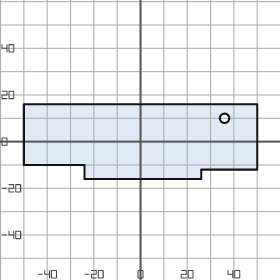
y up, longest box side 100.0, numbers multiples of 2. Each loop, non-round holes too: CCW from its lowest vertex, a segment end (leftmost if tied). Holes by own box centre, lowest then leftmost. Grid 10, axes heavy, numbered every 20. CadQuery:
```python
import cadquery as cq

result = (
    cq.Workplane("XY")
    .moveTo(-24.0, -16.0)
    .lineTo(26.0, -16.0)
    .lineTo(26.0, -12.0)
    .lineTo(50.0, -12.0)
    .lineTo(50.0, 16.0)
    .lineTo(-50.0, 16.0)
    .lineTo(-50.0, -10.0)
    .lineTo(-24.0, -10.0)
    .close()
    .moveTo(36.0, 10.0)
    .circle(2.0)
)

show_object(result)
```